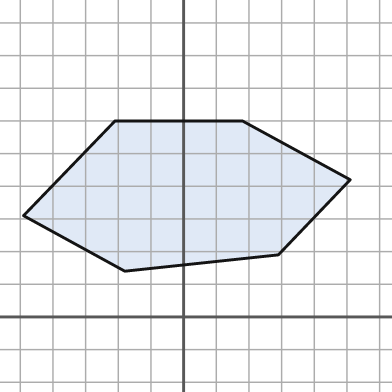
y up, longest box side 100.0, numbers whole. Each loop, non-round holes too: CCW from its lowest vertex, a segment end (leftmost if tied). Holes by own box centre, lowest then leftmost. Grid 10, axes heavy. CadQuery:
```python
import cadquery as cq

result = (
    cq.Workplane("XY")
    .moveTo(-18.0, 14.0)
    .lineTo(29.0, 19.0)
    .lineTo(51.0, 42.0)
    .lineTo(18.0, 60.0)
    .lineTo(-21.0, 60.0)
    .lineTo(-49.0, 31.0)
    .close()
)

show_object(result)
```